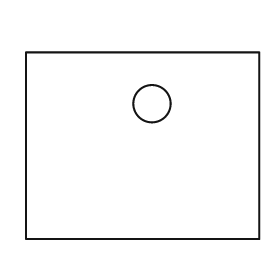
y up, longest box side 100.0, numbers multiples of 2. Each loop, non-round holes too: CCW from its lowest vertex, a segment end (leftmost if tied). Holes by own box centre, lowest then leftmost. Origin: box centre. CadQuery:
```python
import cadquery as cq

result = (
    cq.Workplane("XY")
    .moveTo(-50.0, -40.0)
    .lineTo(50.0, -40.0)
    .lineTo(50.0, 40.0)
    .lineTo(-50.0, 40.0)
    .close()
    .moveTo(4.0, 18.0)
    .circle(8.0)
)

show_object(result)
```